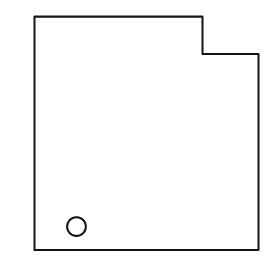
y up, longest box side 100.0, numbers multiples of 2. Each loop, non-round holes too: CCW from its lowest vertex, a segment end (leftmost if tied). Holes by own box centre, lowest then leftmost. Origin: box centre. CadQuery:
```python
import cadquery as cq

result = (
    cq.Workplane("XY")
    .moveTo(-48.0, -50.0)
    .lineTo(48.0, -50.0)
    .lineTo(48.0, 34.0)
    .lineTo(24.0, 34.0)
    .lineTo(24.0, 50.0)
    .lineTo(-48.0, 50.0)
    .close()
    .moveTo(-30.0, -40.0)
    .circle(4.0)
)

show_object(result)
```